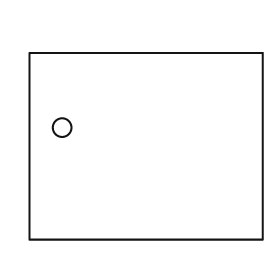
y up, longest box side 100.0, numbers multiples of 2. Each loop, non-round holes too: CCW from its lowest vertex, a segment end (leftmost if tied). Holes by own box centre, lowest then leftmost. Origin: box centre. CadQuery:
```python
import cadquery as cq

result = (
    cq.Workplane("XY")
    .moveTo(-50.0, -40.0)
    .lineTo(50.0, -40.0)
    .lineTo(50.0, 40.0)
    .lineTo(-50.0, 40.0)
    .close()
    .moveTo(-36.0, 8.0)
    .circle(4.0)
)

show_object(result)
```